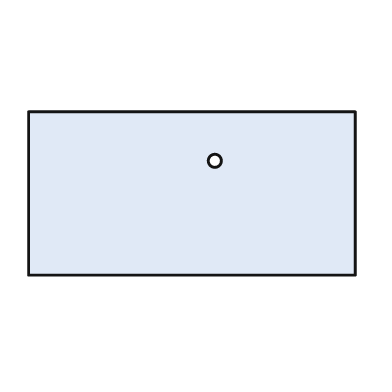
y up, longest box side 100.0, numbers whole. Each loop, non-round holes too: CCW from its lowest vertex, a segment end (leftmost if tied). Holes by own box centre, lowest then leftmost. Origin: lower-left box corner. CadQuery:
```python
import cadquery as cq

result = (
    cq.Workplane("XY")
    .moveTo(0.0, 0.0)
    .lineTo(100.0, 0.0)
    .lineTo(100.0, 50.0)
    .lineTo(0.0, 50.0)
    .close()
    .moveTo(57.0, 35.0)
    .circle(2.0)
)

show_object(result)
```